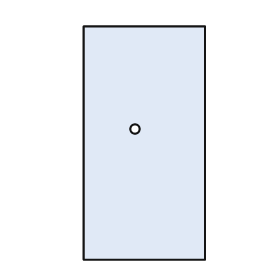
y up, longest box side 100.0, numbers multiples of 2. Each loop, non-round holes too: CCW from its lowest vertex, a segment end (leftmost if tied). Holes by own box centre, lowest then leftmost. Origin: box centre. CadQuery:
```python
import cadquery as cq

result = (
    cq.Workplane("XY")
    .moveTo(-26.0, -50.0)
    .lineTo(26.0, -50.0)
    .lineTo(26.0, 50.0)
    .lineTo(-26.0, 50.0)
    .close()
    .moveTo(-4.0, 6.0)
    .circle(2.0)
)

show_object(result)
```